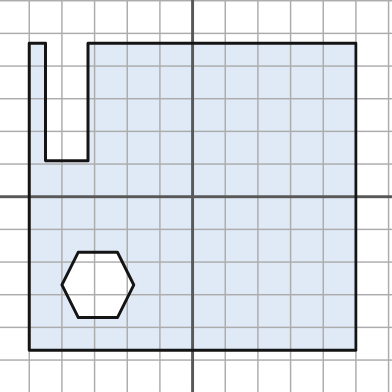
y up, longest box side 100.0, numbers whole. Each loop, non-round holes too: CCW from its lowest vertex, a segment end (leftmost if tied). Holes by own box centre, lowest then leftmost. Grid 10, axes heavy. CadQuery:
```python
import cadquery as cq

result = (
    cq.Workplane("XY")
    .moveTo(-50.0, -47.0)
    .lineTo(50.0, -47.0)
    .lineTo(50.0, 47.0)
    .lineTo(-32.0, 47.0)
    .lineTo(-32.0, 11.0)
    .lineTo(-45.0, 11.0)
    .lineTo(-45.0, 47.0)
    .lineTo(-50.0, 47.0)
    .close()
    .moveTo(-35.0, -37.0)
    .lineTo(-23.0, -37.0)
    .lineTo(-18.0, -27.0)
    .lineTo(-23.0, -17.0)
    .lineTo(-35.0, -17.0)
    .lineTo(-40.0, -27.0)
    .close()
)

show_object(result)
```